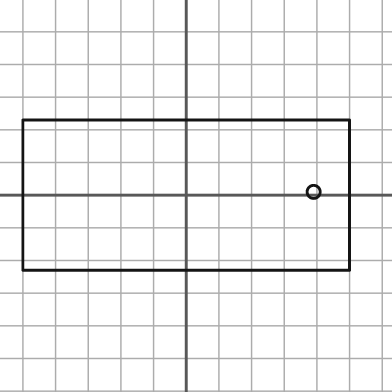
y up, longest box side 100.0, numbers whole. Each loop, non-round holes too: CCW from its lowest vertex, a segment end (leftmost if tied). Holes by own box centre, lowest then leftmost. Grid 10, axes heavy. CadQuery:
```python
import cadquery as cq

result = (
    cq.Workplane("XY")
    .moveTo(-50.0, -23.0)
    .lineTo(50.0, -23.0)
    .lineTo(50.0, 23.0)
    .lineTo(-50.0, 23.0)
    .close()
    .moveTo(39.0, 1.0)
    .circle(2.0)
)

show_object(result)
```